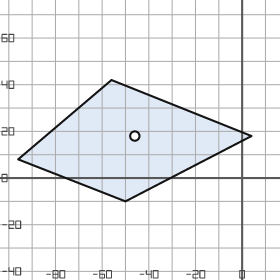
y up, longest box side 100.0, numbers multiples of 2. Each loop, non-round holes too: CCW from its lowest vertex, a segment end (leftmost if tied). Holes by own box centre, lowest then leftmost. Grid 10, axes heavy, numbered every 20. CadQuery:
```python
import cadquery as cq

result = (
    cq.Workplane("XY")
    .moveTo(-50.0, -10.0)
    .lineTo(4.0, 18.0)
    .lineTo(-56.0, 42.0)
    .lineTo(-96.0, 8.0)
    .close()
    .moveTo(-46.0, 18.0)
    .circle(2.0)
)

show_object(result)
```